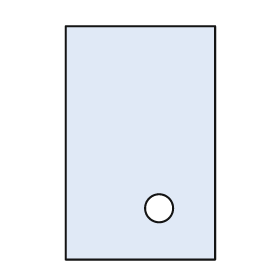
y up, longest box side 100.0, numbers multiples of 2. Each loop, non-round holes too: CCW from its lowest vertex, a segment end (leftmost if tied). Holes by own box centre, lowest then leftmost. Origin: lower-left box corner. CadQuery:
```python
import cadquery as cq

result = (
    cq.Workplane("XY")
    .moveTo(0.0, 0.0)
    .lineTo(64.0, 0.0)
    .lineTo(64.0, 100.0)
    .lineTo(0.0, 100.0)
    .close()
    .moveTo(40.0, 22.0)
    .circle(6.0)
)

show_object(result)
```